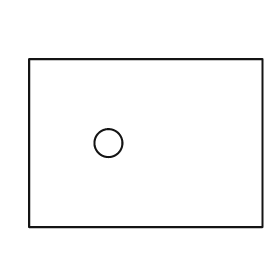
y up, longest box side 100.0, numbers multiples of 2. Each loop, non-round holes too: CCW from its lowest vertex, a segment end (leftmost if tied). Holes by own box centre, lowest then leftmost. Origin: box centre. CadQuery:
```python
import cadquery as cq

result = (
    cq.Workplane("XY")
    .moveTo(-50.0, -36.0)
    .lineTo(50.0, -36.0)
    .lineTo(50.0, 36.0)
    .lineTo(-50.0, 36.0)
    .close()
    .moveTo(-16.0, 0.0)
    .circle(6.0)
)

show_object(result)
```